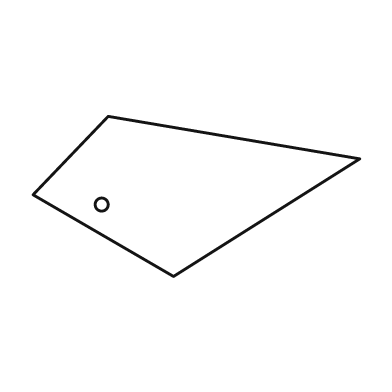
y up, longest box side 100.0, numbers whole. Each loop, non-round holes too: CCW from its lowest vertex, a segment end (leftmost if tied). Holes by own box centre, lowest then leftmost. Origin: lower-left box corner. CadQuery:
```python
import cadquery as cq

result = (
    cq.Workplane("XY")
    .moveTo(43.0, 0.0)
    .lineTo(100.0, 36.0)
    .lineTo(23.0, 49.0)
    .lineTo(0.0, 25.0)
    .close()
    .moveTo(21.0, 22.0)
    .circle(2.0)
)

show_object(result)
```